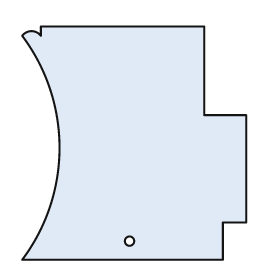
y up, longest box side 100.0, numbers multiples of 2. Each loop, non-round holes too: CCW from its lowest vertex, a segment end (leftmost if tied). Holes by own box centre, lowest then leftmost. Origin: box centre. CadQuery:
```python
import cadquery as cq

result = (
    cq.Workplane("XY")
    .moveTo(-48.0, -50.0)
    .lineTo(38.0, -50.0)
    .lineTo(38.0, -34.0)
    .lineTo(48.0, -34.0)
    .lineTo(48.0, 12.0)
    .lineTo(30.0, 12.0)
    .lineTo(30.0, 50.0)
    .lineTo(-40.0, 50.0)
    .lineTo(-40.0, 46.0)
    .threePointArc((-44.0, 48.0), (-48.0, 46.0))
    .threePointArc((-32.0, -2.0), (-48.0, -50.0))
    .close()
    .moveTo(-2.0, -42.0)
    .circle(2.0)
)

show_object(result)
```